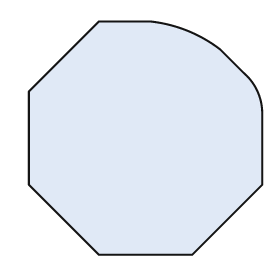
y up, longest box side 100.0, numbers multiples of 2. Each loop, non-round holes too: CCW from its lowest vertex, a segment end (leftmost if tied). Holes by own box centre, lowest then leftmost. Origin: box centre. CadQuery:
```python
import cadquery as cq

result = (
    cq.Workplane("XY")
    .moveTo(-20.0, -50.0)
    .lineTo(20.0, -50.0)
    .lineTo(50.0, -20.0)
    .lineTo(50.0, 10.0)
    .threePointArc((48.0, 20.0), (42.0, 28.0))
    .lineTo(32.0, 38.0)
    .threePointArc((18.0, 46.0), (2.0, 50.0))
    .lineTo(-20.0, 50.0)
    .lineTo(-50.0, 20.0)
    .lineTo(-50.0, -20.0)
    .close()
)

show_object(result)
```